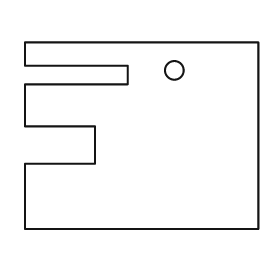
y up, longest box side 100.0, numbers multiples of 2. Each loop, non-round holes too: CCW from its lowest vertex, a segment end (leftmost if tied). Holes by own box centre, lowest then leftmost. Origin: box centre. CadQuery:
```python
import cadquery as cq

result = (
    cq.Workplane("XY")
    .moveTo(-50.0, -40.0)
    .lineTo(50.0, -40.0)
    .lineTo(50.0, 40.0)
    .lineTo(-50.0, 40.0)
    .lineTo(-50.0, 30.0)
    .lineTo(-6.0, 30.0)
    .lineTo(-6.0, 22.0)
    .lineTo(-50.0, 22.0)
    .lineTo(-50.0, 4.0)
    .lineTo(-20.0, 4.0)
    .lineTo(-20.0, -12.0)
    .lineTo(-50.0, -12.0)
    .close()
    .moveTo(14.0, 28.0)
    .circle(4.0)
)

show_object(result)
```